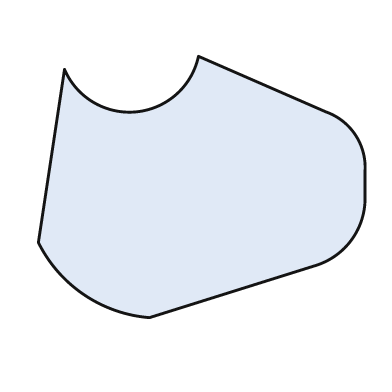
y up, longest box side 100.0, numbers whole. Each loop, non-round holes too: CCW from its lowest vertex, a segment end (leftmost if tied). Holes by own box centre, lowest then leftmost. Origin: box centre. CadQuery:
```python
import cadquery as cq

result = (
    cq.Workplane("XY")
    .moveTo(-16.0, -40.0)
    .lineTo(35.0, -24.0)
    .threePointArc((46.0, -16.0), (50.0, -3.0))
    .lineTo(50.0, 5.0)
    .threePointArc((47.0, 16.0), (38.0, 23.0))
    .lineTo(-1.0, 40.0)
    .threePointArc((-20.0, 23.0), (-42.0, 36.0))
    .lineTo(-50.0, -17.0)
    .threePointArc((-36.0, -33.0), (-16.0, -40.0))
    .close()
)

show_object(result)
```